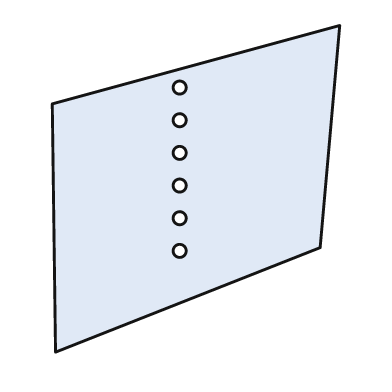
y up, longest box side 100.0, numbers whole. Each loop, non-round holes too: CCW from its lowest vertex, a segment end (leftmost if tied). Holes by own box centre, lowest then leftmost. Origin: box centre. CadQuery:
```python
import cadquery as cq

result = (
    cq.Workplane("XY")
    .moveTo(-43.0, -50.0)
    .lineTo(38.0, -18.0)
    .lineTo(44.0, 50.0)
    .lineTo(-44.0, 26.0)
    .close()
    .moveTo(-5.0, -19.0)
    .circle(2.0)
    .moveTo(-5.0, -9.0)
    .circle(2.0)
    .moveTo(-5.0, 1.0)
    .circle(2.0)
    .moveTo(-5.0, 11.0)
    .circle(2.0)
    .moveTo(-5.0, 21.0)
    .circle(2.0)
    .moveTo(-5.0, 31.0)
    .circle(2.0)
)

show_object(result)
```